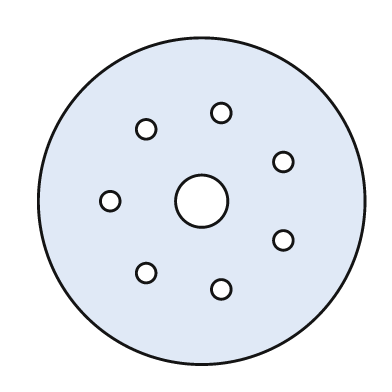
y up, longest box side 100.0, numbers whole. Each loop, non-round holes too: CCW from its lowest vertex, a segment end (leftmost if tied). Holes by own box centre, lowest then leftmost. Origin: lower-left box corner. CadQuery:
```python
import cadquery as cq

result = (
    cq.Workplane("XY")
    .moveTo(50.0, 50.0)
    .circle(50.0)
    .moveTo(56.0, 23.0)
    .circle(3.0)
    .moveTo(33.0, 28.0)
    .circle(3.0)
    .moveTo(75.0, 38.0)
    .circle(3.0)
    .moveTo(22.0, 50.0)
    .circle(3.0)
    .moveTo(50.0, 50.0)
    .circle(8.0)
    .moveTo(75.0, 62.0)
    .circle(3.0)
    .moveTo(33.0, 72.0)
    .circle(3.0)
    .moveTo(56.0, 77.0)
    .circle(3.0)
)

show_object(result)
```